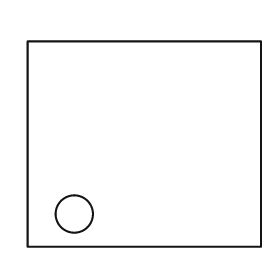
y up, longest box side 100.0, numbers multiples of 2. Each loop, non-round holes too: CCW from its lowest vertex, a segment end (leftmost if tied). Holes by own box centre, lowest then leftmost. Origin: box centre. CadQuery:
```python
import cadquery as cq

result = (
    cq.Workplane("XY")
    .moveTo(-50.0, -44.0)
    .lineTo(50.0, -44.0)
    .lineTo(50.0, 44.0)
    .lineTo(-50.0, 44.0)
    .close()
    .moveTo(-30.0, -30.0)
    .circle(8.0)
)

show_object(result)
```